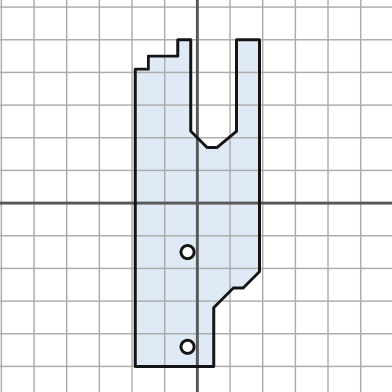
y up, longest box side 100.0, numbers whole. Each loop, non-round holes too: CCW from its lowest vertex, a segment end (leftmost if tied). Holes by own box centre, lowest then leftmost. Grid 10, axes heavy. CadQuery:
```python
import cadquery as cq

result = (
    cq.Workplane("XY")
    .moveTo(-19.0, -50.0)
    .lineTo(5.0, -50.0)
    .lineTo(5.0, -32.0)
    .lineTo(11.0, -26.0)
    .lineTo(14.0, -26.0)
    .lineTo(19.0, -21.0)
    .lineTo(19.0, 50.0)
    .lineTo(12.0, 50.0)
    .lineTo(12.0, 22.0)
    .lineTo(6.0, 17.0)
    .lineTo(3.0, 17.0)
    .lineTo(-2.0, 22.0)
    .lineTo(-2.0, 50.0)
    .lineTo(-6.0, 50.0)
    .lineTo(-6.0, 45.0)
    .lineTo(-15.0, 45.0)
    .lineTo(-15.0, 41.0)
    .lineTo(-19.0, 41.0)
    .close()
    .moveTo(-3.0, -44.0)
    .circle(2.0)
    .moveTo(-3.0, -15.0)
    .circle(2.0)
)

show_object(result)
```